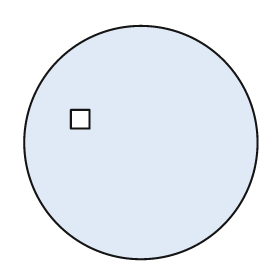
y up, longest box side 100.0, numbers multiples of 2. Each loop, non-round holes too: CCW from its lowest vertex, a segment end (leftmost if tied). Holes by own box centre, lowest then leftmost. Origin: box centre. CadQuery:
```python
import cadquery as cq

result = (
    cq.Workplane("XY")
    .moveTo(0.0, 0.0)
    .circle(50.0)
    .moveTo(-30.0, 6.0)
    .lineTo(-22.0, 6.0)
    .lineTo(-22.0, 14.0)
    .lineTo(-30.0, 14.0)
    .close()
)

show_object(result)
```